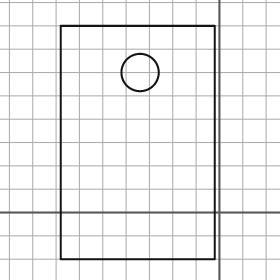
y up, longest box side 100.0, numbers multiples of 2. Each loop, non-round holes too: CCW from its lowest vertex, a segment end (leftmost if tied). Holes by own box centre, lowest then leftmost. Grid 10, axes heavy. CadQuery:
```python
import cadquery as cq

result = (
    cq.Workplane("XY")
    .moveTo(-68.0, -20.0)
    .lineTo(-2.0, -20.0)
    .lineTo(-2.0, 80.0)
    .lineTo(-68.0, 80.0)
    .close()
    .moveTo(-34.0, 60.0)
    .circle(8.0)
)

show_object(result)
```